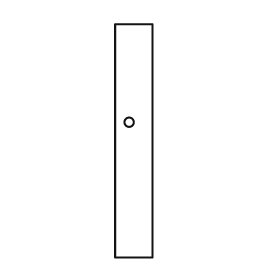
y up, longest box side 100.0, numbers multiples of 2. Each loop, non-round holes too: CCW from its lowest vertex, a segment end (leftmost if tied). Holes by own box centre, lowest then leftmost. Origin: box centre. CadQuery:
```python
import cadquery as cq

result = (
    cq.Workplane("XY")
    .moveTo(-8.0, -50.0)
    .lineTo(8.0, -50.0)
    .lineTo(8.0, 50.0)
    .lineTo(-8.0, 50.0)
    .close()
    .moveTo(-2.0, 8.0)
    .circle(2.0)
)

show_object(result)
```